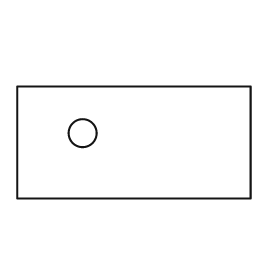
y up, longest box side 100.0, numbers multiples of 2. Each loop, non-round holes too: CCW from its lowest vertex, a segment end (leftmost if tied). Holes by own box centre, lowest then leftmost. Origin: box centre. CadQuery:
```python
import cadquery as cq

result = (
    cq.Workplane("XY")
    .moveTo(-50.0, -24.0)
    .lineTo(50.0, -24.0)
    .lineTo(50.0, 24.0)
    .lineTo(-50.0, 24.0)
    .close()
    .moveTo(-22.0, 4.0)
    .circle(6.0)
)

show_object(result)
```